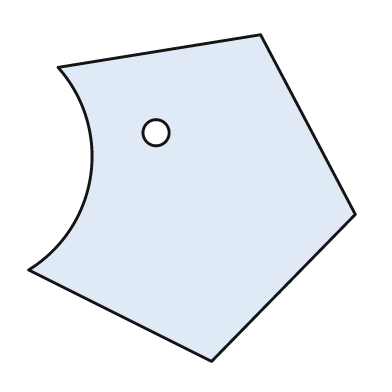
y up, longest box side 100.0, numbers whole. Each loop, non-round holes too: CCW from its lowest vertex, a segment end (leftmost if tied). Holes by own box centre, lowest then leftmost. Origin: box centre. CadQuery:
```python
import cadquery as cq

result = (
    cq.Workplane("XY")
    .moveTo(6.0, -50.0)
    .lineTo(50.0, -5.0)
    .lineTo(21.0, 50.0)
    .lineTo(-41.0, 40.0)
    .threePointArc((-31.0, 7.0), (-50.0, -22.0))
    .close()
    .moveTo(-11.0, 20.0)
    .circle(4.0)
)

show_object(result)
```